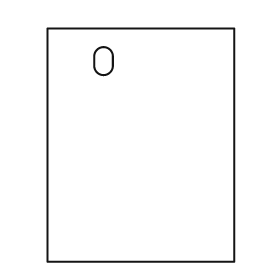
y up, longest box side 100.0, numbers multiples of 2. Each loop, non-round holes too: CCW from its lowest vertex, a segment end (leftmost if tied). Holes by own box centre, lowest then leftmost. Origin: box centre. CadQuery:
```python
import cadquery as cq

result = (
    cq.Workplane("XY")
    .moveTo(-40.0, -50.0)
    .lineTo(40.0, -50.0)
    .lineTo(40.0, 50.0)
    .lineTo(-40.0, 50.0)
    .close()
    .moveTo(-20.0, 34.0)
    .threePointArc((-16.0, 30.0), (-12.0, 34.0))
    .lineTo(-12.0, 38.0)
    .threePointArc((-16.0, 42.0), (-20.0, 38.0))
    .close()
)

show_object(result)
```